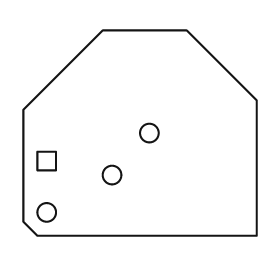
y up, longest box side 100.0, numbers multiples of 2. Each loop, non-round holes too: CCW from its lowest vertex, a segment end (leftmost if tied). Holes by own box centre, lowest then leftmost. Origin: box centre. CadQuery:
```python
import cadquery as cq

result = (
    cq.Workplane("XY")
    .moveTo(-44.0, -44.0)
    .lineTo(50.0, -44.0)
    .lineTo(50.0, 14.0)
    .lineTo(20.0, 44.0)
    .lineTo(-16.0, 44.0)
    .lineTo(-50.0, 10.0)
    .lineTo(-50.0, -38.0)
    .close()
    .moveTo(-40.0, -34.0)
    .circle(4.0)
    .moveTo(-12.0, -18.0)
    .circle(4.0)
    .moveTo(-44.0, -16.0)
    .lineTo(-36.0, -16.0)
    .lineTo(-36.0, -8.0)
    .lineTo(-44.0, -8.0)
    .close()
    .moveTo(4.0, 0.0)
    .circle(4.0)
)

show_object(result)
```